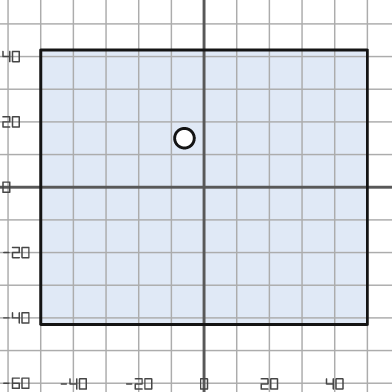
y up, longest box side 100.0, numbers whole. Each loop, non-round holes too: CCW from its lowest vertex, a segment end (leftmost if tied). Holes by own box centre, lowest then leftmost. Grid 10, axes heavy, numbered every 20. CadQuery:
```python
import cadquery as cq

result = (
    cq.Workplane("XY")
    .moveTo(-50.0, -42.0)
    .lineTo(50.0, -42.0)
    .lineTo(50.0, 42.0)
    .lineTo(-50.0, 42.0)
    .close()
    .moveTo(-6.0, 15.0)
    .circle(3.0)
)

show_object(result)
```